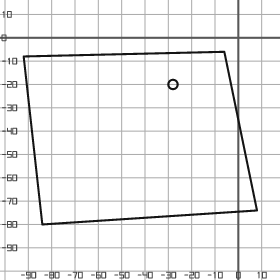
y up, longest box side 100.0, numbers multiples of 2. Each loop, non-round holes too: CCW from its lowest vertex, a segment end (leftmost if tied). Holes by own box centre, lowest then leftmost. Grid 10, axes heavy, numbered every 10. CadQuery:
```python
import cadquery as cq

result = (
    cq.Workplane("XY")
    .moveTo(-84.0, -80.0)
    .lineTo(8.0, -74.0)
    .lineTo(-6.0, -6.0)
    .lineTo(-92.0, -8.0)
    .close()
    .moveTo(-28.0, -20.0)
    .circle(2.0)
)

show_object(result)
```